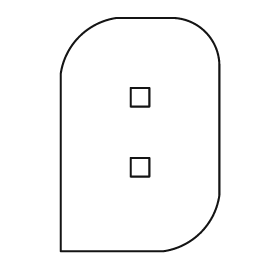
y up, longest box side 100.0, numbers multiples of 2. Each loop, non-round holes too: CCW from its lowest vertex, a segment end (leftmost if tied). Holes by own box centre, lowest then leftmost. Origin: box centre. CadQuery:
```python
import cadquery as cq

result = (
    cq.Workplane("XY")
    .moveTo(-34.0, -50.0)
    .lineTo(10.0, -50.0)
    .threePointArc((26.0, -42.0), (34.0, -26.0))
    .lineTo(34.0, 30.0)
    .threePointArc((28.0, 44.0), (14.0, 50.0))
    .lineTo(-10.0, 50.0)
    .threePointArc((-26.0, 42.0), (-34.0, 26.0))
    .close()
    .moveTo(-4.0, -18.0)
    .lineTo(4.0, -18.0)
    .lineTo(4.0, -10.0)
    .lineTo(-4.0, -10.0)
    .close()
    .moveTo(-4.0, 12.0)
    .lineTo(4.0, 12.0)
    .lineTo(4.0, 20.0)
    .lineTo(-4.0, 20.0)
    .close()
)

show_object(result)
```